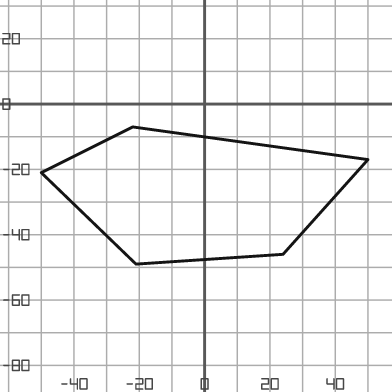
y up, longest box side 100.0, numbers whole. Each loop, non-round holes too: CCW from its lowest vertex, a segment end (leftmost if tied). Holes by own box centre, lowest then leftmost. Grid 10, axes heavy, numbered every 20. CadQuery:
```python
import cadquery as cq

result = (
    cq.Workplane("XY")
    .moveTo(-21.0, -49.0)
    .lineTo(24.0, -46.0)
    .lineTo(50.0, -17.0)
    .lineTo(-22.0, -7.0)
    .lineTo(-50.0, -21.0)
    .close()
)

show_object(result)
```